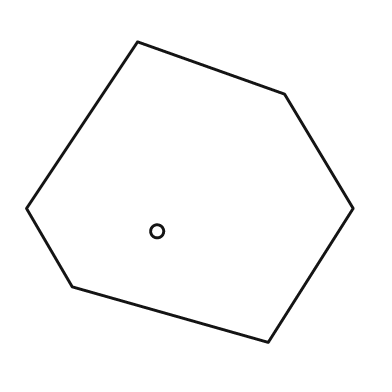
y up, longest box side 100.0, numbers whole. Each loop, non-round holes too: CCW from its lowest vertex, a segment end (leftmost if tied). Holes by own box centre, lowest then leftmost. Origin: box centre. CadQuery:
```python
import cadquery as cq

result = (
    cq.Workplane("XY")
    .moveTo(24.0, -46.0)
    .lineTo(50.0, -5.0)
    .lineTo(29.0, 30.0)
    .lineTo(-16.0, 46.0)
    .lineTo(-50.0, -5.0)
    .lineTo(-36.0, -29.0)
    .close()
    .moveTo(-10.0, -12.0)
    .circle(2.0)
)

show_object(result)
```